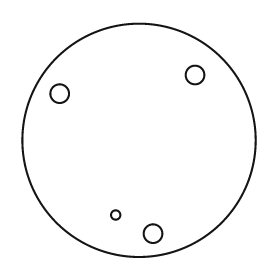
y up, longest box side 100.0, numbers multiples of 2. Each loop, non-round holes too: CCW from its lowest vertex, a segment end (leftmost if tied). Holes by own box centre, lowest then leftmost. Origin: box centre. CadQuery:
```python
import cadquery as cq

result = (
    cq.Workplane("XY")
    .moveTo(0.0, 0.0)
    .circle(50.0)
    .moveTo(6.0, -40.0)
    .circle(4.0)
    .moveTo(-10.0, -32.0)
    .circle(2.0)
    .moveTo(-34.0, 20.0)
    .circle(4.0)
    .moveTo(24.0, 28.0)
    .circle(4.0)
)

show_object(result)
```